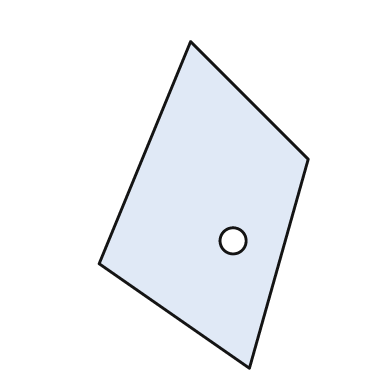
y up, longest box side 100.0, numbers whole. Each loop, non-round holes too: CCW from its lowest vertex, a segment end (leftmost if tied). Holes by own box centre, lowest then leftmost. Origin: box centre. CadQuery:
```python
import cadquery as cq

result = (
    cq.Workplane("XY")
    .moveTo(14.0, -50.0)
    .lineTo(32.0, 14.0)
    .lineTo(-4.0, 50.0)
    .lineTo(-32.0, -18.0)
    .close()
    .moveTo(9.0, -11.0)
    .circle(4.0)
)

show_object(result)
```